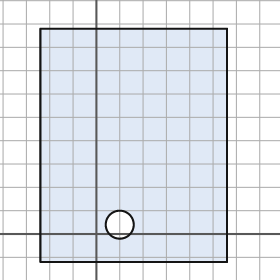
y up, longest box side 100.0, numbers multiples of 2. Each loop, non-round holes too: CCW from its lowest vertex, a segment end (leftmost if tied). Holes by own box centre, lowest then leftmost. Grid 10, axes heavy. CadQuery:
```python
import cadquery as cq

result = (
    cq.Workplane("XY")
    .moveTo(-24.0, -12.0)
    .lineTo(56.0, -12.0)
    .lineTo(56.0, 88.0)
    .lineTo(-24.0, 88.0)
    .close()
    .moveTo(10.0, 4.0)
    .circle(6.0)
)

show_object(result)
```